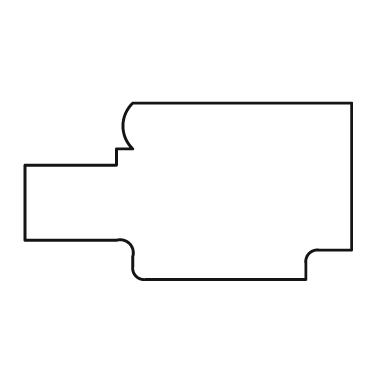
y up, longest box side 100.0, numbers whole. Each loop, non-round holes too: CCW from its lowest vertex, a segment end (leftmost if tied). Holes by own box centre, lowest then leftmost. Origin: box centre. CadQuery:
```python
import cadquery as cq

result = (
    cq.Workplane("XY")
    .moveTo(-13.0, -27.0)
    .lineTo(36.0, -27.0)
    .lineTo(36.0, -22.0)
    .threePointArc((37.0, -19.0), (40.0, -18.0))
    .lineTo(50.0, -18.0)
    .lineTo(50.0, 27.0)
    .lineTo(-17.0, 27.0)
    .threePointArc((-20.0, 20.0), (-17.0, 13.0))
    .lineTo(-22.0, 13.0)
    .lineTo(-22.0, 8.0)
    .lineTo(-50.0, 8.0)
    .lineTo(-50.0, -15.0)
    .lineTo(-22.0, -15.0)
    .threePointArc((-18.0, -16.0), (-17.0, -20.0))
    .lineTo(-17.0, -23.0)
    .threePointArc((-16.0, -26.0), (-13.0, -27.0))
    .close()
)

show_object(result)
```